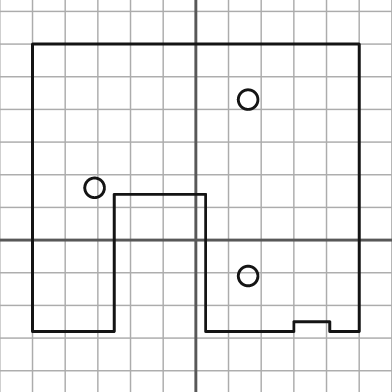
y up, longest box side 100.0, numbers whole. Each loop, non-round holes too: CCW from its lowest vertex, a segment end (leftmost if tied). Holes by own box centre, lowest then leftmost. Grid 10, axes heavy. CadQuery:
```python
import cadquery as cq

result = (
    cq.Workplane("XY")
    .moveTo(-50.0, -28.0)
    .lineTo(-25.0, -28.0)
    .lineTo(-25.0, 14.0)
    .lineTo(3.0, 14.0)
    .lineTo(3.0, -28.0)
    .lineTo(30.0, -28.0)
    .lineTo(30.0, -25.0)
    .lineTo(41.0, -25.0)
    .lineTo(41.0, -28.0)
    .lineTo(50.0, -28.0)
    .lineTo(50.0, 60.0)
    .lineTo(-50.0, 60.0)
    .close()
    .moveTo(16.0, -11.0)
    .circle(3.0)
    .moveTo(-31.0, 16.0)
    .circle(3.0)
    .moveTo(16.0, 43.0)
    .circle(3.0)
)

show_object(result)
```